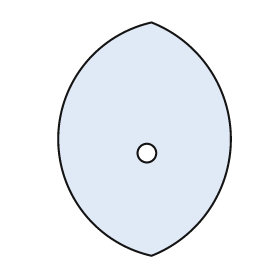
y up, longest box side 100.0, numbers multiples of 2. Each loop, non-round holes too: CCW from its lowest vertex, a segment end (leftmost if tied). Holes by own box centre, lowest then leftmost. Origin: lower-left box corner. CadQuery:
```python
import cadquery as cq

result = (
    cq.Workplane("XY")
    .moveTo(40.0, 0.0)
    .threePointArc((74.0, 50.0), (40.0, 100.0))
    .threePointArc((0.0, 50.0), (40.0, 0.0))
    .close()
    .moveTo(38.0, 44.0)
    .circle(4.0)
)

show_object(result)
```